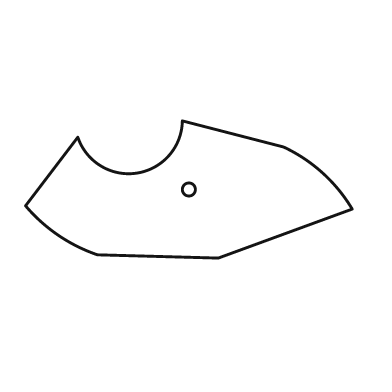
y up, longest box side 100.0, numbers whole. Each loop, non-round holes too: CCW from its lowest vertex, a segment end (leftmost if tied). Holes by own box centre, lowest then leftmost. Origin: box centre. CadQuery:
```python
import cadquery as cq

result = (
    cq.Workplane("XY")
    .moveTo(9.0, -21.0)
    .lineTo(50.0, -6.0)
    .threePointArc((41.0, 5.0), (29.0, 13.0))
    .lineTo(-2.0, 21.0)
    .threePointArc((-16.0, 5.0), (-34.0, 16.0))
    .lineTo(-50.0, -5.0)
    .threePointArc((-40.0, -14.0), (-28.0, -20.0))
    .close()
    .moveTo(0.0, 0.0)
    .circle(2.0)
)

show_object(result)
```